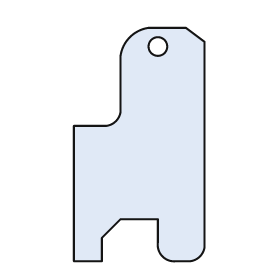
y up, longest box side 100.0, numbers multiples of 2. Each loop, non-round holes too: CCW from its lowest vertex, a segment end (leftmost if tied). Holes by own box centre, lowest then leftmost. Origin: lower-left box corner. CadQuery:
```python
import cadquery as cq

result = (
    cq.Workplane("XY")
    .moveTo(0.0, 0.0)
    .lineTo(12.0, 0.0)
    .lineTo(12.0, 10.0)
    .lineTo(20.0, 18.0)
    .lineTo(36.0, 18.0)
    .lineTo(36.0, 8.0)
    .threePointArc((38.0, 2.0), (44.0, 0.0))
    .lineTo(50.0, 0.0)
    .threePointArc((54.0, 2.0), (56.0, 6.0))
    .lineTo(56.0, 94.0)
    .lineTo(48.0, 100.0)
    .lineTo(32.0, 100.0)
    .threePointArc((24.0, 96.0), (20.0, 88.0))
    .lineTo(20.0, 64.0)
    .threePointArc((18.0, 60.0), (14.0, 58.0))
    .lineTo(0.0, 58.0)
    .close()
    .moveTo(36.0, 92.0)
    .circle(4.0)
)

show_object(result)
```